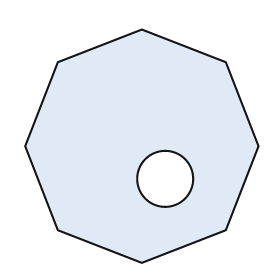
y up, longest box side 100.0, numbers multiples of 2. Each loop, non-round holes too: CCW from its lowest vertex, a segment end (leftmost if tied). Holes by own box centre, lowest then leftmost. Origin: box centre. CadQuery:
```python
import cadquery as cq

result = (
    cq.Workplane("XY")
    .moveTo(0.0, -50.0)
    .lineTo(36.0, -36.0)
    .lineTo(50.0, 0.0)
    .lineTo(36.0, 36.0)
    .lineTo(0.0, 50.0)
    .lineTo(-36.0, 36.0)
    .lineTo(-50.0, 0.0)
    .lineTo(-36.0, -36.0)
    .close()
    .moveTo(10.0, -14.0)
    .circle(12.0)
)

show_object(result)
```